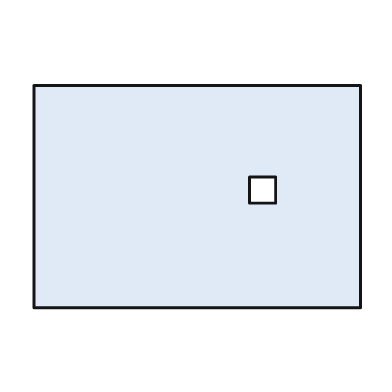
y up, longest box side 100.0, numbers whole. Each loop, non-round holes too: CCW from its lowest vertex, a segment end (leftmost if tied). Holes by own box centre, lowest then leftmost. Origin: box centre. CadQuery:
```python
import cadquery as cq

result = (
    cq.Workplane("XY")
    .moveTo(-50.0, -34.0)
    .lineTo(50.0, -34.0)
    .lineTo(50.0, 34.0)
    .lineTo(-50.0, 34.0)
    .close()
    .moveTo(16.0, -2.0)
    .lineTo(24.0, -2.0)
    .lineTo(24.0, 6.0)
    .lineTo(16.0, 6.0)
    .close()
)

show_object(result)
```